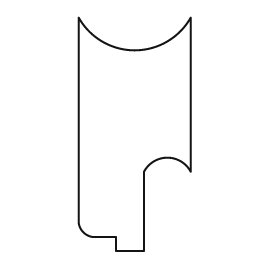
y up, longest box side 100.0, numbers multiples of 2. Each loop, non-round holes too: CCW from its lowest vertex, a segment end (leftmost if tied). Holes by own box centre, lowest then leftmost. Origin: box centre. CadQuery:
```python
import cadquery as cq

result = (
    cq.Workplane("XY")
    .moveTo(-8.0, -50.0)
    .lineTo(4.0, -50.0)
    .lineTo(4.0, -16.0)
    .threePointArc((14.0, -10.0), (24.0, -16.0))
    .lineTo(24.0, 50.0)
    .threePointArc((0.0, 36.0), (-24.0, 50.0))
    .lineTo(-24.0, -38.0)
    .threePointArc((-22.0, -42.0), (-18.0, -44.0))
    .lineTo(-8.0, -44.0)
    .close()
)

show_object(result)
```